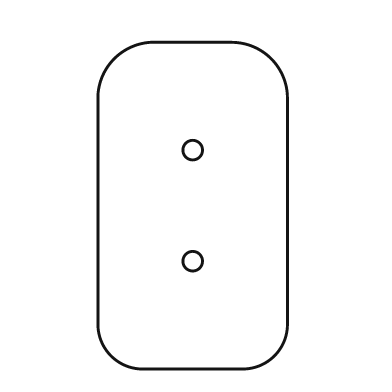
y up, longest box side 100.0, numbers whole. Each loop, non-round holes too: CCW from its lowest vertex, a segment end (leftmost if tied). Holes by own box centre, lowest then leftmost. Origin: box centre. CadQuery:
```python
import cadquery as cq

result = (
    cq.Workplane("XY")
    .moveTo(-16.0, -50.0)
    .lineTo(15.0, -50.0)
    .threePointArc((25.0, -46.0), (29.0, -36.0))
    .lineTo(29.0, 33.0)
    .threePointArc((24.0, 45.0), (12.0, 50.0))
    .lineTo(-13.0, 50.0)
    .threePointArc((-24.0, 45.0), (-29.0, 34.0))
    .lineTo(-29.0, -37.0)
    .threePointArc((-25.0, -46.0), (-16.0, -50.0))
    .close()
    .moveTo(0.0, -17.0)
    .circle(3.0)
    .moveTo(0.0, 17.0)
    .circle(3.0)
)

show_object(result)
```